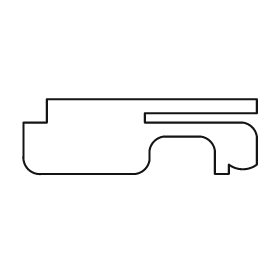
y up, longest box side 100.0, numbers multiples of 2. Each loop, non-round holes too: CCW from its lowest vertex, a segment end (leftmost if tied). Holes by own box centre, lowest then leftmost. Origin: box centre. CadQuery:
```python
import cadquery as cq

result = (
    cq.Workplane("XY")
    .moveTo(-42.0, -16.0)
    .lineTo(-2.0, -16.0)
    .threePointArc((2.0, -14.0), (4.0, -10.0))
    .lineTo(4.0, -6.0)
    .threePointArc((6.0, -2.0), (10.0, 0.0))
    .lineTo(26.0, 0.0)
    .threePointArc((30.0, -2.0), (32.0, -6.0))
    .lineTo(32.0, -16.0)
    .lineTo(38.0, -16.0)
    .lineTo(38.0, -12.0)
    .threePointArc((44.0, -14.0), (50.0, -12.0))
    .lineTo(50.0, 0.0)
    .threePointArc((48.0, 4.0), (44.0, 6.0))
    .lineTo(2.0, 6.0)
    .lineTo(2.0, 10.0)
    .lineTo(50.0, 10.0)
    .lineTo(50.0, 16.0)
    .lineTo(-40.0, 16.0)
    .lineTo(-40.0, 6.0)
    .lineTo(-50.0, 6.0)
    .lineTo(-50.0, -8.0)
    .threePointArc((-48.0, -14.0), (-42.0, -16.0))
    .close()
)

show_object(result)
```